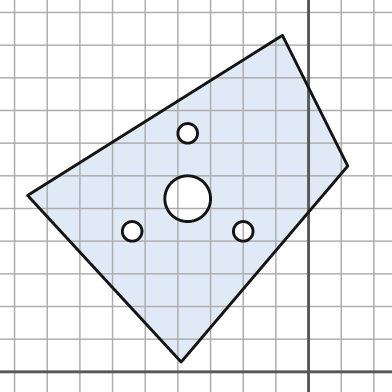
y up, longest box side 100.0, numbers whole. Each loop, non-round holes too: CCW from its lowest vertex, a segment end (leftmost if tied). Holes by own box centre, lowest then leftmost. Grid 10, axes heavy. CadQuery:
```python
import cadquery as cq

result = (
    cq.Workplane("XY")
    .moveTo(-39.0, 3.0)
    .lineTo(12.0, 63.0)
    .lineTo(-8.0, 103.0)
    .lineTo(-86.0, 54.0)
    .close()
    .moveTo(-54.0, 43.0)
    .circle(3.0)
    .moveTo(-20.0, 43.0)
    .circle(3.0)
    .moveTo(-37.0, 53.0)
    .circle(7.0)
    .moveTo(-37.0, 73.0)
    .circle(3.0)
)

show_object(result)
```